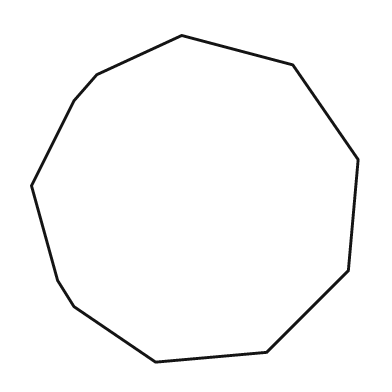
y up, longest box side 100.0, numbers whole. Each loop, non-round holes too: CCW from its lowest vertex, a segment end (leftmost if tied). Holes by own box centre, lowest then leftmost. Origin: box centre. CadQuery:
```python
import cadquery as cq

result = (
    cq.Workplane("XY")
    .moveTo(-12.0, -50.0)
    .lineTo(22.0, -47.0)
    .lineTo(47.0, -22.0)
    .lineTo(50.0, 12.0)
    .lineTo(30.0, 41.0)
    .lineTo(-4.0, 50.0)
    .lineTo(-30.0, 38.0)
    .lineTo(-37.0, 30.0)
    .lineTo(-50.0, 4.0)
    .lineTo(-42.0, -25.0)
    .lineTo(-37.0, -33.0)
    .close()
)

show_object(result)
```